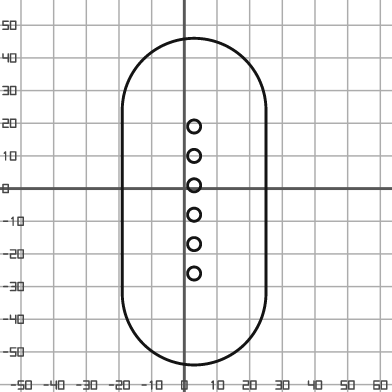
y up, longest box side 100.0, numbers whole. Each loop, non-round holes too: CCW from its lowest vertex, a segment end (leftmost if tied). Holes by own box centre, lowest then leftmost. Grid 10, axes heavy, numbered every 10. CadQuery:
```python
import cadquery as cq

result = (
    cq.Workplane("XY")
    .moveTo(-19.0, -32.0)
    .threePointArc((3.0, -54.0), (25.0, -32.0))
    .lineTo(25.0, 24.0)
    .threePointArc((3.0, 46.0), (-19.0, 24.0))
    .close()
    .moveTo(3.0, -26.0)
    .circle(2.0)
    .moveTo(3.0, -17.0)
    .circle(2.0)
    .moveTo(3.0, -8.0)
    .circle(2.0)
    .moveTo(3.0, 1.0)
    .circle(2.0)
    .moveTo(3.0, 10.0)
    .circle(2.0)
    .moveTo(3.0, 19.0)
    .circle(2.0)
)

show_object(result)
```